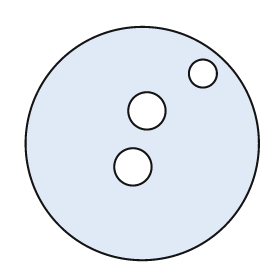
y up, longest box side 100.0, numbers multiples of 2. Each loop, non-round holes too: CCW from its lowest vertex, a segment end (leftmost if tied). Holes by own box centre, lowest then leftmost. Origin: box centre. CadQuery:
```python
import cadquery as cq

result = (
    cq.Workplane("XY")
    .moveTo(0.0, 0.0)
    .circle(50.0)
    .moveTo(-4.0, -10.0)
    .circle(8.0)
    .moveTo(2.0, 14.0)
    .circle(8.0)
    .moveTo(26.0, 30.0)
    .circle(6.0)
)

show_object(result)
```